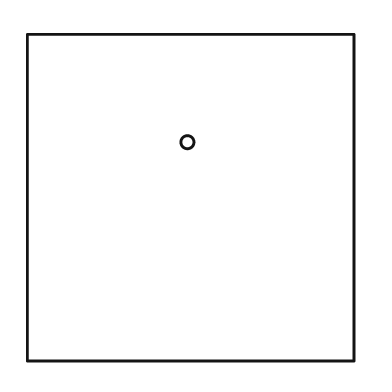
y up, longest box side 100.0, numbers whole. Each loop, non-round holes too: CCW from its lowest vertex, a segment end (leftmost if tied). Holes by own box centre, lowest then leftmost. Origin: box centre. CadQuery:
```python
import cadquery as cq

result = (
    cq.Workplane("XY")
    .moveTo(-50.0, -50.0)
    .lineTo(50.0, -50.0)
    .lineTo(50.0, 50.0)
    .lineTo(-50.0, 50.0)
    .close()
    .moveTo(-1.0, 17.0)
    .circle(2.0)
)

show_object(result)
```